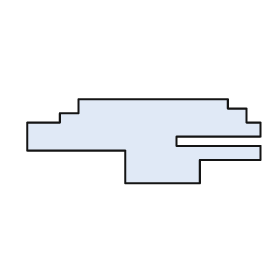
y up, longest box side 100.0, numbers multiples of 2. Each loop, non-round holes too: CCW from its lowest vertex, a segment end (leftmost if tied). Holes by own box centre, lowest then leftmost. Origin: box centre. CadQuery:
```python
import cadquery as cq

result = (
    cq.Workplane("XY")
    .moveTo(-8.0, -18.0)
    .lineTo(24.0, -18.0)
    .lineTo(24.0, -8.0)
    .lineTo(50.0, -8.0)
    .lineTo(50.0, -2.0)
    .lineTo(14.0, -2.0)
    .lineTo(14.0, 2.0)
    .lineTo(50.0, 2.0)
    .lineTo(50.0, 8.0)
    .lineTo(44.0, 8.0)
    .lineTo(44.0, 14.0)
    .lineTo(36.0, 14.0)
    .lineTo(36.0, 18.0)
    .lineTo(-28.0, 18.0)
    .lineTo(-28.0, 12.0)
    .lineTo(-36.0, 12.0)
    .lineTo(-36.0, 8.0)
    .lineTo(-50.0, 8.0)
    .lineTo(-50.0, -4.0)
    .lineTo(-8.0, -4.0)
    .close()
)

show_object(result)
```